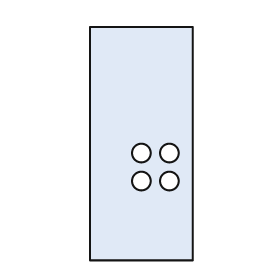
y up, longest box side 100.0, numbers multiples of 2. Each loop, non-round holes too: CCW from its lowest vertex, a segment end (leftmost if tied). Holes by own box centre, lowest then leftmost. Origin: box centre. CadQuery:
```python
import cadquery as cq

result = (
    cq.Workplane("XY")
    .moveTo(-22.0, -50.0)
    .lineTo(22.0, -50.0)
    .lineTo(22.0, 50.0)
    .lineTo(-22.0, 50.0)
    .close()
    .moveTo(0.0, -16.0)
    .circle(4.0)
    .moveTo(12.0, -16.0)
    .circle(4.0)
    .moveTo(0.0, -4.0)
    .circle(4.0)
    .moveTo(12.0, -4.0)
    .circle(4.0)
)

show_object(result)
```